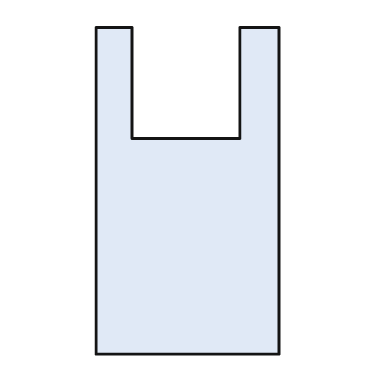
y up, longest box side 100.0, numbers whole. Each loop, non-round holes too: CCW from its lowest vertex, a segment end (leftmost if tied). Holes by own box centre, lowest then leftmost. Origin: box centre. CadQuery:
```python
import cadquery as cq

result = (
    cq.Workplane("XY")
    .moveTo(-28.0, -50.0)
    .lineTo(28.0, -50.0)
    .lineTo(28.0, 50.0)
    .lineTo(16.0, 50.0)
    .lineTo(16.0, 16.0)
    .lineTo(-17.0, 16.0)
    .lineTo(-17.0, 50.0)
    .lineTo(-28.0, 50.0)
    .close()
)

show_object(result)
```